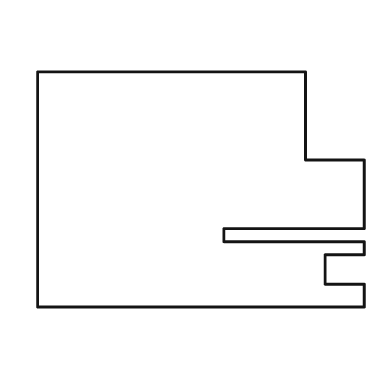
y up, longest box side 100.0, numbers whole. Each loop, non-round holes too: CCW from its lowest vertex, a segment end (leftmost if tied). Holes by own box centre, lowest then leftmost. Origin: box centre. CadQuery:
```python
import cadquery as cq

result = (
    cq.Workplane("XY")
    .moveTo(-50.0, -36.0)
    .lineTo(50.0, -36.0)
    .lineTo(50.0, -29.0)
    .lineTo(38.0, -29.0)
    .lineTo(38.0, -20.0)
    .lineTo(50.0, -20.0)
    .lineTo(50.0, -16.0)
    .lineTo(7.0, -16.0)
    .lineTo(7.0, -12.0)
    .lineTo(50.0, -12.0)
    .lineTo(50.0, 9.0)
    .lineTo(32.0, 9.0)
    .lineTo(32.0, 36.0)
    .lineTo(-50.0, 36.0)
    .close()
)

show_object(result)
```